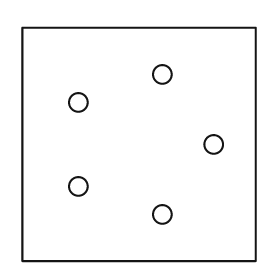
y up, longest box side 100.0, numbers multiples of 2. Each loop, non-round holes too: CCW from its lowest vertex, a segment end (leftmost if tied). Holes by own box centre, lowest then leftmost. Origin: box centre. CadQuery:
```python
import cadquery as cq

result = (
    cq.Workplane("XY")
    .moveTo(-50.0, -50.0)
    .lineTo(50.0, -50.0)
    .lineTo(50.0, 50.0)
    .lineTo(-50.0, 50.0)
    .close()
    .moveTo(10.0, -30.0)
    .circle(4.0)
    .moveTo(-26.0, -18.0)
    .circle(4.0)
    .moveTo(32.0, 0.0)
    .circle(4.0)
    .moveTo(-26.0, 18.0)
    .circle(4.0)
    .moveTo(10.0, 30.0)
    .circle(4.0)
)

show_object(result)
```